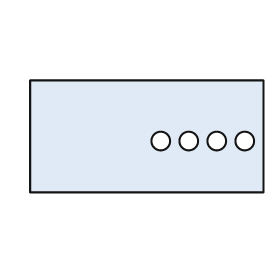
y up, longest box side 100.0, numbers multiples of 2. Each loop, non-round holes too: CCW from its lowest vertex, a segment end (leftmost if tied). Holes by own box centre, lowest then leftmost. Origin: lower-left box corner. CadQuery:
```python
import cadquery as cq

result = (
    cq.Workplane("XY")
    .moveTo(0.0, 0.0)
    .lineTo(100.0, 0.0)
    .lineTo(100.0, 48.0)
    .lineTo(0.0, 48.0)
    .close()
    .moveTo(56.0, 22.0)
    .circle(4.0)
    .moveTo(68.0, 22.0)
    .circle(4.0)
    .moveTo(80.0, 22.0)
    .circle(4.0)
    .moveTo(92.0, 22.0)
    .circle(4.0)
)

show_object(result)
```